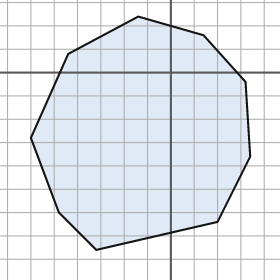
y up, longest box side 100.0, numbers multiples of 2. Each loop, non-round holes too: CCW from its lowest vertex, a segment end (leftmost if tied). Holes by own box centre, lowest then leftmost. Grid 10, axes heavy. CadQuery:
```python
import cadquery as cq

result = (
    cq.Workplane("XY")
    .moveTo(-32.0, -76.0)
    .lineTo(20.0, -64.0)
    .lineTo(34.0, -36.0)
    .lineTo(32.0, -4.0)
    .lineTo(14.0, 16.0)
    .lineTo(-14.0, 24.0)
    .lineTo(-44.0, 8.0)
    .lineTo(-60.0, -28.0)
    .lineTo(-48.0, -60.0)
    .close()
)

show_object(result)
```